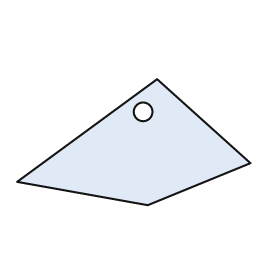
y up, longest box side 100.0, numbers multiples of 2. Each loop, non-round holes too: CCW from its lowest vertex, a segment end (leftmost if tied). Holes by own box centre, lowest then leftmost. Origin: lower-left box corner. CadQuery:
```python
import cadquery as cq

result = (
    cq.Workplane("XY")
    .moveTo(56.0, 0.0)
    .lineTo(100.0, 18.0)
    .lineTo(60.0, 54.0)
    .lineTo(0.0, 10.0)
    .close()
    .moveTo(54.0, 40.0)
    .circle(4.0)
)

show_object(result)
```